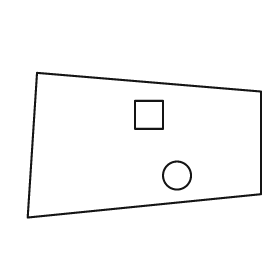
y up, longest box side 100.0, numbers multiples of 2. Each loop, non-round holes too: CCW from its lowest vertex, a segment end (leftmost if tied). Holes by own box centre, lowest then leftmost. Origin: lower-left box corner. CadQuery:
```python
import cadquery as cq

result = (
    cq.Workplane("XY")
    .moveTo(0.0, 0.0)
    .lineTo(100.0, 10.0)
    .lineTo(100.0, 54.0)
    .lineTo(4.0, 62.0)
    .close()
    .moveTo(64.0, 18.0)
    .circle(6.0)
    .moveTo(46.0, 38.0)
    .lineTo(58.0, 38.0)
    .lineTo(58.0, 50.0)
    .lineTo(46.0, 50.0)
    .close()
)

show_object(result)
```